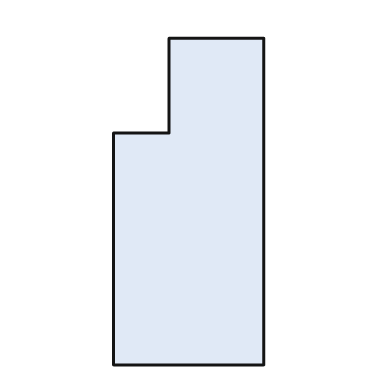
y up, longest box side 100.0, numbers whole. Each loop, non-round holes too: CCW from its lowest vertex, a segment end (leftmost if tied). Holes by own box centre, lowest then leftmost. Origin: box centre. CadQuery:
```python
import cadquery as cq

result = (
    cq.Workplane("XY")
    .moveTo(-23.0, -50.0)
    .lineTo(23.0, -50.0)
    .lineTo(23.0, 50.0)
    .lineTo(-6.0, 50.0)
    .lineTo(-6.0, 21.0)
    .lineTo(-23.0, 21.0)
    .close()
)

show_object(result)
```